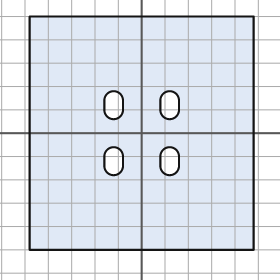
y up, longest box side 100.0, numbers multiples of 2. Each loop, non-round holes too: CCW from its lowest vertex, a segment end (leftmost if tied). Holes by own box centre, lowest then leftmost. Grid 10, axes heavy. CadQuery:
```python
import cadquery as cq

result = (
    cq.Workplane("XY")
    .moveTo(-48.0, -50.0)
    .lineTo(48.0, -50.0)
    .lineTo(48.0, 50.0)
    .lineTo(-48.0, 50.0)
    .close()
    .moveTo(-16.0, -14.0)
    .threePointArc((-12.0, -18.0), (-8.0, -14.0))
    .lineTo(-8.0, -10.0)
    .threePointArc((-12.0, -6.0), (-16.0, -10.0))
    .close()
    .moveTo(8.0, -14.0)
    .threePointArc((12.0, -18.0), (16.0, -14.0))
    .lineTo(16.0, -10.0)
    .threePointArc((12.0, -6.0), (8.0, -10.0))
    .close()
    .moveTo(-16.0, 10.0)
    .threePointArc((-12.0, 6.0), (-8.0, 10.0))
    .lineTo(-8.0, 14.0)
    .threePointArc((-12.0, 18.0), (-16.0, 14.0))
    .close()
    .moveTo(8.0, 10.0)
    .threePointArc((12.0, 6.0), (16.0, 10.0))
    .lineTo(16.0, 14.0)
    .threePointArc((12.0, 18.0), (8.0, 14.0))
    .close()
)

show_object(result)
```